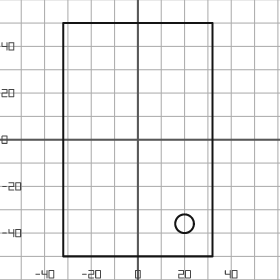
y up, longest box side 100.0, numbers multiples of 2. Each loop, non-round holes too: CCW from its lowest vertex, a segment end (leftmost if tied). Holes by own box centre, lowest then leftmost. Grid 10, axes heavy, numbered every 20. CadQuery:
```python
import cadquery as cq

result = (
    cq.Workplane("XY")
    .moveTo(-32.0, -50.0)
    .lineTo(32.0, -50.0)
    .lineTo(32.0, 50.0)
    .lineTo(-32.0, 50.0)
    .close()
    .moveTo(20.0, -36.0)
    .circle(4.0)
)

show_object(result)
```